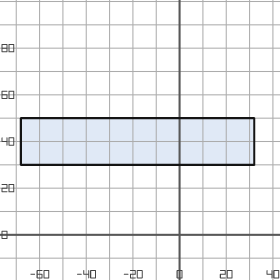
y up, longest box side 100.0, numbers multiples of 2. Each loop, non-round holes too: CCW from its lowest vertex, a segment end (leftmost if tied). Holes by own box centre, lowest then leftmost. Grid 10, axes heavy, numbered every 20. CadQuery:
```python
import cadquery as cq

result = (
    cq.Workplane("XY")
    .moveTo(-68.0, 30.0)
    .lineTo(32.0, 30.0)
    .lineTo(32.0, 50.0)
    .lineTo(-68.0, 50.0)
    .close()
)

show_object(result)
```